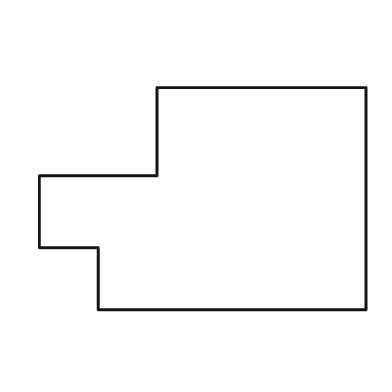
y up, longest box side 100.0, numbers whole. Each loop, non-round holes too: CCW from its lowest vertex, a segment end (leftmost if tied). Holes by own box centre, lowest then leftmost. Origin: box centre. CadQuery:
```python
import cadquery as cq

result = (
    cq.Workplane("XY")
    .moveTo(-32.0, -34.0)
    .lineTo(50.0, -34.0)
    .lineTo(50.0, 34.0)
    .lineTo(-14.0, 34.0)
    .lineTo(-14.0, 7.0)
    .lineTo(-50.0, 7.0)
    .lineTo(-50.0, -15.0)
    .lineTo(-32.0, -15.0)
    .close()
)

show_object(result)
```